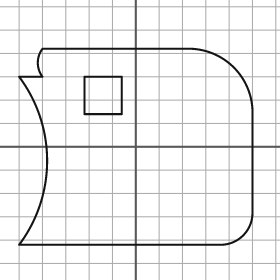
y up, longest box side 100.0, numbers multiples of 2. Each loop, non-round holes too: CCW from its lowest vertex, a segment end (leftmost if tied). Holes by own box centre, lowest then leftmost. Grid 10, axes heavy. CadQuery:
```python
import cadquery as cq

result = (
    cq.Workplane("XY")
    .moveTo(-50.0, -42.0)
    .lineTo(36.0, -42.0)
    .threePointArc((46.0, -38.0), (50.0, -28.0))
    .lineTo(50.0, 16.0)
    .threePointArc((42.0, 34.0), (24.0, 42.0))
    .lineTo(-40.0, 42.0)
    .threePointArc((-42.0, 36.0), (-40.0, 30.0))
    .lineTo(-50.0, 30.0)
    .threePointArc((-38.0, -6.0), (-50.0, -42.0))
    .close()
    .moveTo(-22.0, 14.0)
    .lineTo(-6.0, 14.0)
    .lineTo(-6.0, 30.0)
    .lineTo(-22.0, 30.0)
    .close()
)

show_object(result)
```